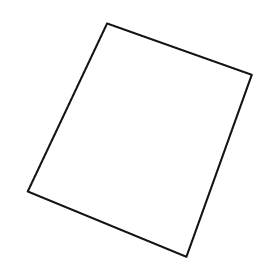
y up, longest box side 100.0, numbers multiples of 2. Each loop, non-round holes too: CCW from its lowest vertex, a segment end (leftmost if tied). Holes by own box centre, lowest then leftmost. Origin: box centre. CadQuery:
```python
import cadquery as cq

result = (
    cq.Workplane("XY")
    .moveTo(20.0, -50.0)
    .lineTo(48.0, 28.0)
    .lineTo(-14.0, 50.0)
    .lineTo(-48.0, -22.0)
    .close()
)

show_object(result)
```